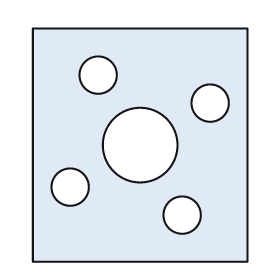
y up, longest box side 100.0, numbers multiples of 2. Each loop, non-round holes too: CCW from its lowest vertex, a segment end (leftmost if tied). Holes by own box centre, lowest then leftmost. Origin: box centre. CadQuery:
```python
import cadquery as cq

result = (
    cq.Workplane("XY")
    .moveTo(-46.0, -50.0)
    .lineTo(46.0, -50.0)
    .lineTo(46.0, 50.0)
    .lineTo(-46.0, 50.0)
    .close()
    .moveTo(18.0, -30.0)
    .circle(8.0)
    .moveTo(-30.0, -18.0)
    .circle(8.0)
    .moveTo(0.0, 0.0)
    .circle(16.0)
    .moveTo(30.0, 18.0)
    .circle(8.0)
    .moveTo(-18.0, 30.0)
    .circle(8.0)
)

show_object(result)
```